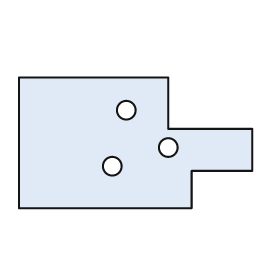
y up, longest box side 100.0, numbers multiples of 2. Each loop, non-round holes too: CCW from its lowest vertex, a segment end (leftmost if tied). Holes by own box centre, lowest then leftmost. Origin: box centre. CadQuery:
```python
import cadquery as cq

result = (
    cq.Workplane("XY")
    .moveTo(-50.0, -28.0)
    .lineTo(24.0, -28.0)
    .lineTo(24.0, -12.0)
    .lineTo(50.0, -12.0)
    .lineTo(50.0, 6.0)
    .lineTo(14.0, 6.0)
    .lineTo(14.0, 28.0)
    .lineTo(-50.0, 28.0)
    .close()
    .moveTo(-10.0, -10.0)
    .circle(4.0)
    .moveTo(14.0, -2.0)
    .circle(4.0)
    .moveTo(-4.0, 14.0)
    .circle(4.0)
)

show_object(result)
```